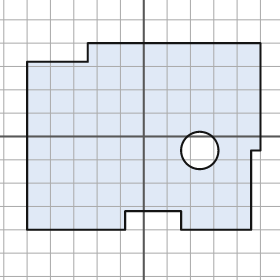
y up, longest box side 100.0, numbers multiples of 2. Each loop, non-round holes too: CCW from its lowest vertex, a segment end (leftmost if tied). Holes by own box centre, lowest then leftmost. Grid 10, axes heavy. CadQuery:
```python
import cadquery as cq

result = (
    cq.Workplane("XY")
    .moveTo(-50.0, -40.0)
    .lineTo(-8.0, -40.0)
    .lineTo(-8.0, -32.0)
    .lineTo(16.0, -32.0)
    .lineTo(16.0, -40.0)
    .lineTo(46.0, -40.0)
    .lineTo(46.0, -6.0)
    .lineTo(50.0, -6.0)
    .lineTo(50.0, 40.0)
    .lineTo(-24.0, 40.0)
    .lineTo(-24.0, 32.0)
    .lineTo(-50.0, 32.0)
    .close()
    .moveTo(24.0, -6.0)
    .circle(8.0)
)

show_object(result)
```